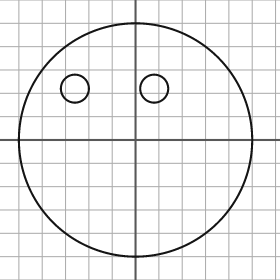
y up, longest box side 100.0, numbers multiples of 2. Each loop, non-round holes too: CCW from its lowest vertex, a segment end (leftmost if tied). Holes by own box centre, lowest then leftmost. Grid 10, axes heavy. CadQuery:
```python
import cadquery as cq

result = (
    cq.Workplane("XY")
    .moveTo(0.0, 0.0)
    .circle(50.0)
    .moveTo(-26.0, 22.0)
    .circle(6.0)
    .moveTo(8.0, 22.0)
    .circle(6.0)
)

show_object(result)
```